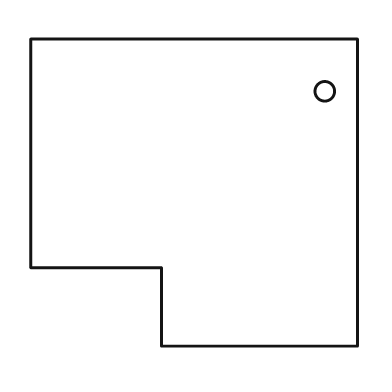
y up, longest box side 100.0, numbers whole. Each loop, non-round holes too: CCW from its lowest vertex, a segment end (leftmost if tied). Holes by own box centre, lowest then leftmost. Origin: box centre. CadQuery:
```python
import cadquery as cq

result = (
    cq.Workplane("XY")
    .moveTo(-10.0, -47.0)
    .lineTo(50.0, -47.0)
    .lineTo(50.0, 47.0)
    .lineTo(-50.0, 47.0)
    .lineTo(-50.0, -23.0)
    .lineTo(-10.0, -23.0)
    .close()
    .moveTo(40.0, 31.0)
    .circle(3.0)
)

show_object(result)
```